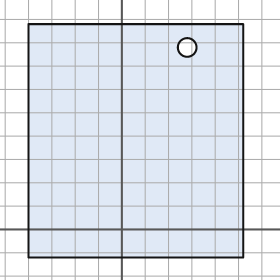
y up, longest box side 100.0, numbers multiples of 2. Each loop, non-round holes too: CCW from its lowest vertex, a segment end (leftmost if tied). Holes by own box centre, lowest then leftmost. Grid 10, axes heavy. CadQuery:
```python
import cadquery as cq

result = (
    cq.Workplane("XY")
    .moveTo(-40.0, -12.0)
    .lineTo(52.0, -12.0)
    .lineTo(52.0, 88.0)
    .lineTo(-40.0, 88.0)
    .close()
    .moveTo(28.0, 78.0)
    .circle(4.0)
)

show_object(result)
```